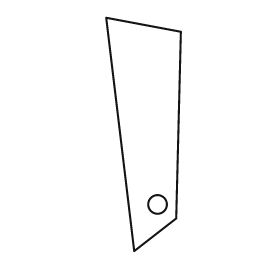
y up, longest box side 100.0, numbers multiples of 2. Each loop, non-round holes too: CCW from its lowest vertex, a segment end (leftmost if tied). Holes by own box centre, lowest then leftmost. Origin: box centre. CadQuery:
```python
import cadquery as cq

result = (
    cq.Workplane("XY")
    .moveTo(-4.0, -50.0)
    .lineTo(14.0, -36.0)
    .lineTo(16.0, 44.0)
    .lineTo(-16.0, 50.0)
    .close()
    .moveTo(6.0, -30.0)
    .circle(4.0)
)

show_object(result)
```